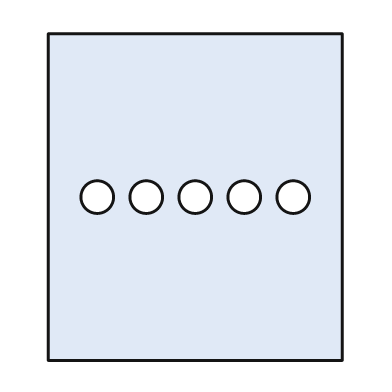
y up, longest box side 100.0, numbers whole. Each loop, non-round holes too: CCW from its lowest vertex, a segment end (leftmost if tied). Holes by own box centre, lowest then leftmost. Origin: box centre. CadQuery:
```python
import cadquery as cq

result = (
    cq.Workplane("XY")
    .moveTo(-45.0, -50.0)
    .lineTo(45.0, -50.0)
    .lineTo(45.0, 50.0)
    .lineTo(-45.0, 50.0)
    .close()
    .moveTo(-30.0, 0.0)
    .circle(5.0)
    .moveTo(-15.0, 0.0)
    .circle(5.0)
    .moveTo(0.0, 0.0)
    .circle(5.0)
    .moveTo(15.0, 0.0)
    .circle(5.0)
    .moveTo(30.0, 0.0)
    .circle(5.0)
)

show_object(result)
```